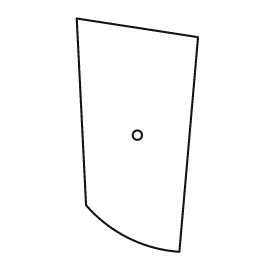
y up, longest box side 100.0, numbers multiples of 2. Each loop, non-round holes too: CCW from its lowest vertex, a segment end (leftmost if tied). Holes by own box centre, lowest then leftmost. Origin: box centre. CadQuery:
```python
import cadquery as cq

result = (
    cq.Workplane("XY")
    .moveTo(18.0, -50.0)
    .lineTo(26.0, 42.0)
    .lineTo(-26.0, 50.0)
    .lineTo(-22.0, -30.0)
    .threePointArc((-4.0, -44.0), (18.0, -50.0))
    .close()
    .moveTo(0.0, 0.0)
    .circle(2.0)
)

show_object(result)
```